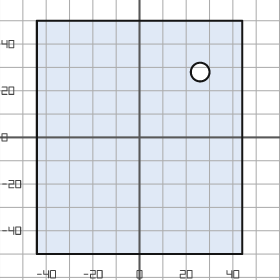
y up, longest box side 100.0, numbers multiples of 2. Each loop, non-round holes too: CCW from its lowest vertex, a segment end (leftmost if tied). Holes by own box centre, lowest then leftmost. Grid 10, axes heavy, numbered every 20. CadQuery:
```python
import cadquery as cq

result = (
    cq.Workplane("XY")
    .moveTo(-44.0, -50.0)
    .lineTo(44.0, -50.0)
    .lineTo(44.0, 50.0)
    .lineTo(-44.0, 50.0)
    .close()
    .moveTo(26.0, 28.0)
    .circle(4.0)
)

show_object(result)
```